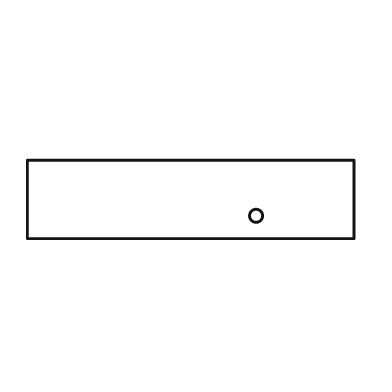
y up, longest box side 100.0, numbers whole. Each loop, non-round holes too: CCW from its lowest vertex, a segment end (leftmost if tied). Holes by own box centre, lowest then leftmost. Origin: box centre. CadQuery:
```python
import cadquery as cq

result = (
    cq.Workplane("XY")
    .moveTo(-50.0, -12.0)
    .lineTo(50.0, -12.0)
    .lineTo(50.0, 12.0)
    .lineTo(-50.0, 12.0)
    .close()
    .moveTo(20.0, -5.0)
    .circle(2.0)
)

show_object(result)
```